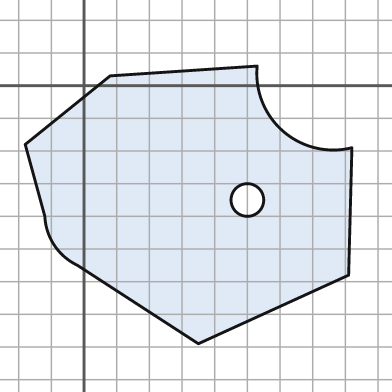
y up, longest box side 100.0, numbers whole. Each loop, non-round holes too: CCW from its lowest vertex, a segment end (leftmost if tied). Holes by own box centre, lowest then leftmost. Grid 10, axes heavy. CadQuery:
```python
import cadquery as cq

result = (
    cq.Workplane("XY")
    .moveTo(35.0, -79.0)
    .lineTo(81.0, -58.0)
    .lineTo(82.0, -19.0)
    .threePointArc((61.0, -14.0), (53.0, 6.0))
    .lineTo(8.0, 3.0)
    .lineTo(-18.0, -18.0)
    .lineTo(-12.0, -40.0)
    .threePointArc((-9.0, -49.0), (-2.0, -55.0))
    .close()
    .moveTo(50.0, -35.0)
    .circle(5.0)
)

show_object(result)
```